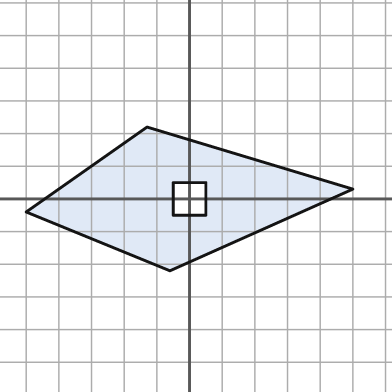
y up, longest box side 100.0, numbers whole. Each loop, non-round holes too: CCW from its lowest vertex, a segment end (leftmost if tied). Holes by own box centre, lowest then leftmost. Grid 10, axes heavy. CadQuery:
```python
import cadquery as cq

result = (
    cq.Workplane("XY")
    .moveTo(-6.0, -22.0)
    .lineTo(50.0, 3.0)
    .lineTo(-13.0, 22.0)
    .lineTo(-50.0, -4.0)
    .close()
    .moveTo(-5.0, -5.0)
    .lineTo(5.0, -5.0)
    .lineTo(5.0, 5.0)
    .lineTo(-5.0, 5.0)
    .close()
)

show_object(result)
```